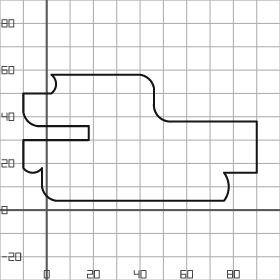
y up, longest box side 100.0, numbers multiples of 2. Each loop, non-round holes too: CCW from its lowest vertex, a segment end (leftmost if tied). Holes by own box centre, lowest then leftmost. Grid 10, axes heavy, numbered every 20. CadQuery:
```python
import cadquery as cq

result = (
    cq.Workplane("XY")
    .moveTo(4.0, 4.0)
    .lineTo(76.0, 4.0)
    .threePointArc((78.0, 10.0), (76.0, 16.0))
    .lineTo(90.0, 16.0)
    .lineTo(90.0, 38.0)
    .lineTo(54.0, 38.0)
    .threePointArc((48.0, 40.0), (46.0, 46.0))
    .lineTo(46.0, 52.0)
    .threePointArc((44.0, 56.0), (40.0, 58.0))
    .lineTo(2.0, 58.0)
    .threePointArc((4.0, 54.0), (2.0, 50.0))
    .lineTo(-10.0, 50.0)
    .lineTo(-10.0, 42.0)
    .threePointArc((-8.0, 38.0), (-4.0, 36.0))
    .lineTo(18.0, 36.0)
    .lineTo(18.0, 30.0)
    .lineTo(-10.0, 30.0)
    .lineTo(-10.0, 18.0)
    .threePointArc((-6.0, 16.0), (-2.0, 18.0))
    .lineTo(-2.0, 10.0)
    .threePointArc((0.0, 6.0), (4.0, 4.0))
    .close()
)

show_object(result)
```